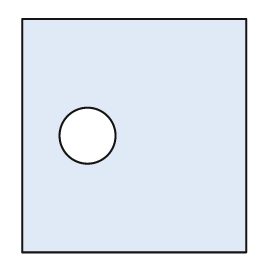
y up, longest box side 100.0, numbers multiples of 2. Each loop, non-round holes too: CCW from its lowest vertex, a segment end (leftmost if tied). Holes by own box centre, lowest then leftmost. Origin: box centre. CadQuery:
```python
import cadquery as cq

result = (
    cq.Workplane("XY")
    .moveTo(-48.0, -50.0)
    .lineTo(48.0, -50.0)
    .lineTo(48.0, 50.0)
    .lineTo(-48.0, 50.0)
    .close()
    .moveTo(-20.0, 0.0)
    .circle(12.0)
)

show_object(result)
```